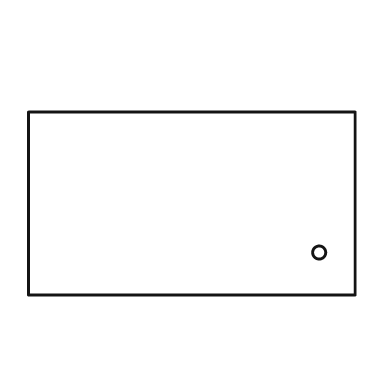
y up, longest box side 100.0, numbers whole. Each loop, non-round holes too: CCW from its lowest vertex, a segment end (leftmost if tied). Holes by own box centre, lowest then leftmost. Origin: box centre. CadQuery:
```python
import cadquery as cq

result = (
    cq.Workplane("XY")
    .moveTo(-50.0, -28.0)
    .lineTo(50.0, -28.0)
    .lineTo(50.0, 28.0)
    .lineTo(-50.0, 28.0)
    .close()
    .moveTo(39.0, -15.0)
    .circle(2.0)
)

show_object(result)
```